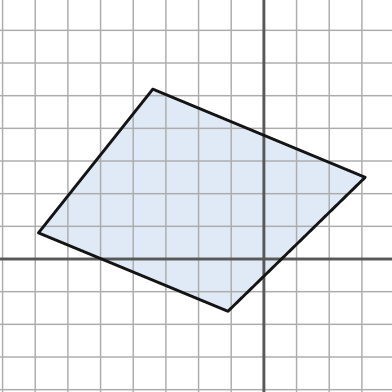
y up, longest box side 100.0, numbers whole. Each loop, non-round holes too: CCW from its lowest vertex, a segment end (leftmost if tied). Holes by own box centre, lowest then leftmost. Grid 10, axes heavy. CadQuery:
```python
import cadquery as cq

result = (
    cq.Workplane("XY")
    .moveTo(-11.0, -16.0)
    .lineTo(31.0, 25.0)
    .lineTo(-34.0, 52.0)
    .lineTo(-69.0, 8.0)
    .close()
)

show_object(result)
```